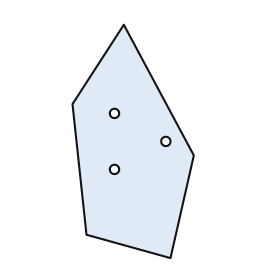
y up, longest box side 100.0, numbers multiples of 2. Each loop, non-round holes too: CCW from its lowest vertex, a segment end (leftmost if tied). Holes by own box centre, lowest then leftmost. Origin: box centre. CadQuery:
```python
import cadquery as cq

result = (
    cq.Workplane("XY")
    .moveTo(16.0, -50.0)
    .lineTo(26.0, -6.0)
    .lineTo(-4.0, 50.0)
    .lineTo(-26.0, 16.0)
    .lineTo(-20.0, -40.0)
    .close()
    .moveTo(-8.0, -12.0)
    .circle(2.0)
    .moveTo(14.0, 0.0)
    .circle(2.0)
    .moveTo(-8.0, 12.0)
    .circle(2.0)
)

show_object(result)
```